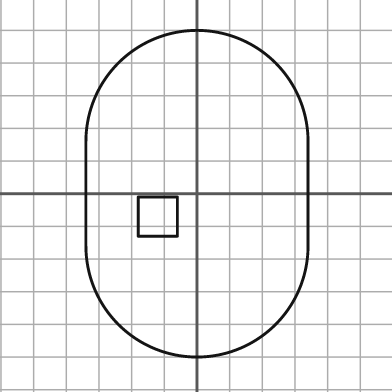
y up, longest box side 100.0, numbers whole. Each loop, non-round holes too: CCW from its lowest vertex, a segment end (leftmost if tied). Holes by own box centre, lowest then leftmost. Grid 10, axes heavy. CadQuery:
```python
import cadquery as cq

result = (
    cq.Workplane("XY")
    .moveTo(-34.0, -16.0)
    .threePointArc((0.0, -50.0), (34.0, -16.0))
    .lineTo(34.0, 16.0)
    .threePointArc((0.0, 50.0), (-34.0, 16.0))
    .close()
    .moveTo(-18.0, -13.0)
    .lineTo(-6.0, -13.0)
    .lineTo(-6.0, -1.0)
    .lineTo(-18.0, -1.0)
    .close()
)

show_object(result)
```